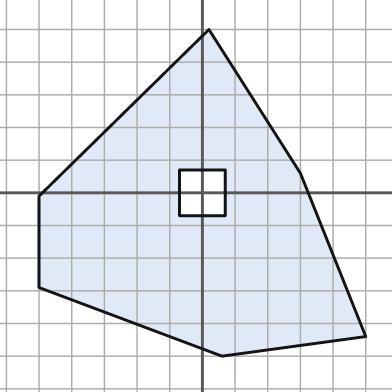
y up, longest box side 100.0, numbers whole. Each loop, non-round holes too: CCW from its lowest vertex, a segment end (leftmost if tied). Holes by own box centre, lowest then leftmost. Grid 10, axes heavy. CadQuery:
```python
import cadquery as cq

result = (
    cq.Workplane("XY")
    .moveTo(6.0, -50.0)
    .lineTo(50.0, -44.0)
    .lineTo(30.0, 6.0)
    .lineTo(2.0, 50.0)
    .lineTo(-50.0, -1.0)
    .lineTo(-50.0, -29.0)
    .close()
    .moveTo(-7.0, -7.0)
    .lineTo(7.0, -7.0)
    .lineTo(7.0, 7.0)
    .lineTo(-7.0, 7.0)
    .close()
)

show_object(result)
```